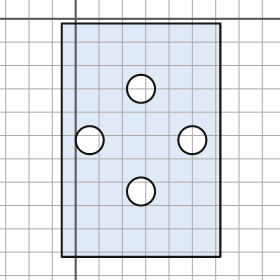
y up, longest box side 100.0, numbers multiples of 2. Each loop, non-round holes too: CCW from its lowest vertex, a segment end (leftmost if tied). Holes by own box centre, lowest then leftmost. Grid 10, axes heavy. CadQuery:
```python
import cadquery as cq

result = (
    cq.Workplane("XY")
    .moveTo(-6.0, -102.0)
    .lineTo(62.0, -102.0)
    .lineTo(62.0, -2.0)
    .lineTo(-6.0, -2.0)
    .close()
    .moveTo(28.0, -74.0)
    .circle(6.0)
    .moveTo(6.0, -52.0)
    .circle(6.0)
    .moveTo(50.0, -52.0)
    .circle(6.0)
    .moveTo(28.0, -30.0)
    .circle(6.0)
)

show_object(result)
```